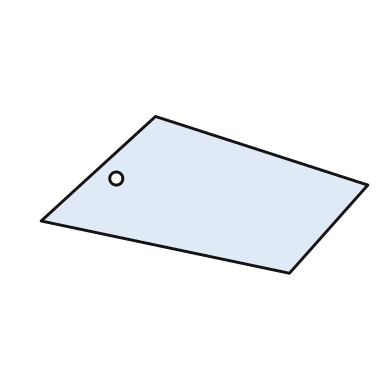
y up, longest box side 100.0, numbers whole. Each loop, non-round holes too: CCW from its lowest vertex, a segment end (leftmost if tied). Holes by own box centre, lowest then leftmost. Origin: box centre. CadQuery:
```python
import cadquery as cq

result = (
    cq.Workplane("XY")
    .moveTo(26.0, -24.0)
    .lineTo(50.0, 3.0)
    .lineTo(-15.0, 24.0)
    .lineTo(-50.0, -8.0)
    .close()
    .moveTo(-27.0, 5.0)
    .circle(2.0)
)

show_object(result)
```